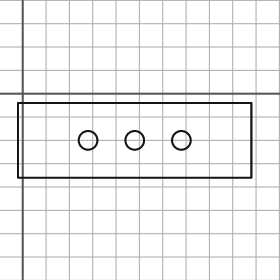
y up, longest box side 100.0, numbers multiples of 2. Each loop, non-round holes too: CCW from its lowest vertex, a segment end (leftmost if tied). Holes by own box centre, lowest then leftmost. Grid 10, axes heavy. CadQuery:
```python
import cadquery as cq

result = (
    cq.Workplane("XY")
    .moveTo(-2.0, -36.0)
    .lineTo(98.0, -36.0)
    .lineTo(98.0, -4.0)
    .lineTo(-2.0, -4.0)
    .close()
    .moveTo(28.0, -20.0)
    .circle(4.0)
    .moveTo(48.0, -20.0)
    .circle(4.0)
    .moveTo(68.0, -20.0)
    .circle(4.0)
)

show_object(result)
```